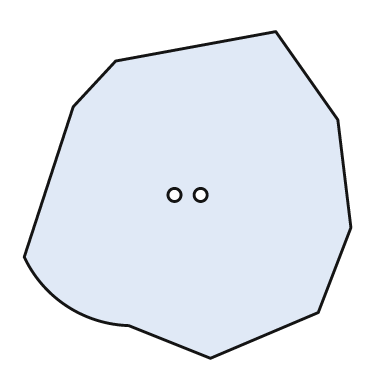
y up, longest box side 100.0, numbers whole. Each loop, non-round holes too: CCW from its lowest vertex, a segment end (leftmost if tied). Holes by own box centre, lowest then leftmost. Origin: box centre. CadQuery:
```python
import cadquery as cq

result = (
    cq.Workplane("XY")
    .moveTo(7.0, -50.0)
    .lineTo(40.0, -36.0)
    .lineTo(50.0, -10.0)
    .lineTo(46.0, 23.0)
    .lineTo(27.0, 50.0)
    .lineTo(-22.0, 41.0)
    .lineTo(-35.0, 27.0)
    .lineTo(-50.0, -19.0)
    .threePointArc((-37.0, -34.0), (-18.0, -40.0))
    .close()
    .moveTo(-4.0, 0.0)
    .circle(2.0)
    .moveTo(4.0, 0.0)
    .circle(2.0)
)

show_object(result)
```